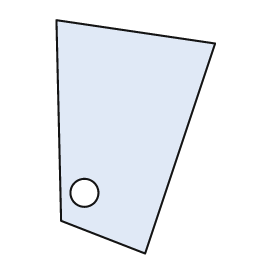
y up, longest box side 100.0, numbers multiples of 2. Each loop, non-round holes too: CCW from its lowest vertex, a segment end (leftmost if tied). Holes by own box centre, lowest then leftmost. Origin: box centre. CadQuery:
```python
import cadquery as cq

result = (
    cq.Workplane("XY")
    .moveTo(4.0, -50.0)
    .lineTo(34.0, 40.0)
    .lineTo(-34.0, 50.0)
    .lineTo(-32.0, -36.0)
    .close()
    .moveTo(-22.0, -24.0)
    .circle(6.0)
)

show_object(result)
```